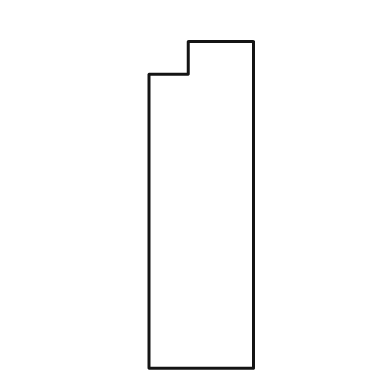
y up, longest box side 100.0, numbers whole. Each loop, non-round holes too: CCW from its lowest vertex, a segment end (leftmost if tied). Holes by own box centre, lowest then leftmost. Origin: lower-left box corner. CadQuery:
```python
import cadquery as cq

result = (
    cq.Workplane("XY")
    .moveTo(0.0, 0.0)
    .lineTo(32.0, 0.0)
    .lineTo(32.0, 100.0)
    .lineTo(12.0, 100.0)
    .lineTo(12.0, 90.0)
    .lineTo(0.0, 90.0)
    .close()
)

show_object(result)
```